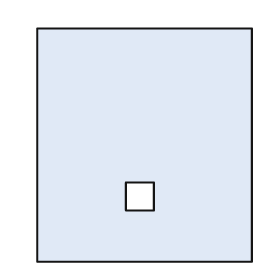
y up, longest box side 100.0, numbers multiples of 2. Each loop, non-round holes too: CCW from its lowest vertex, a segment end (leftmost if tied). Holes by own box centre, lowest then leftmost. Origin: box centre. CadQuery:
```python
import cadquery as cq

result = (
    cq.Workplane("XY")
    .moveTo(-46.0, -50.0)
    .lineTo(46.0, -50.0)
    .lineTo(46.0, 50.0)
    .lineTo(-46.0, 50.0)
    .close()
    .moveTo(-8.0, -28.0)
    .lineTo(4.0, -28.0)
    .lineTo(4.0, -16.0)
    .lineTo(-8.0, -16.0)
    .close()
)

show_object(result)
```